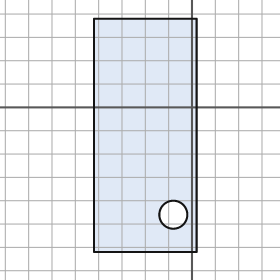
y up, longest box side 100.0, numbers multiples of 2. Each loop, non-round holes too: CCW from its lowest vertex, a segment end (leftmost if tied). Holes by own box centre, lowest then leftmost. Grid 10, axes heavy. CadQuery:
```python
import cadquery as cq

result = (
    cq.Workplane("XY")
    .moveTo(-42.0, -62.0)
    .lineTo(2.0, -62.0)
    .lineTo(2.0, 38.0)
    .lineTo(-42.0, 38.0)
    .close()
    .moveTo(-8.0, -46.0)
    .circle(6.0)
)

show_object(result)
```